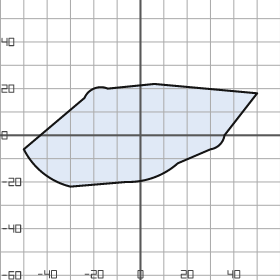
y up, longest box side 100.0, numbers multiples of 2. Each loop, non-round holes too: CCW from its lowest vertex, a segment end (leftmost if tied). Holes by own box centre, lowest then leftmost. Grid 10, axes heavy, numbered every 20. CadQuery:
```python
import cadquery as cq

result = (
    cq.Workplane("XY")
    .moveTo(-30.0, -22.0)
    .lineTo(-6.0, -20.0)
    .threePointArc((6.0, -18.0), (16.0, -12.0))
    .lineTo(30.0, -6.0)
    .threePointArc((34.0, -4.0), (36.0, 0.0))
    .lineTo(50.0, 18.0)
    .lineTo(6.0, 22.0)
    .lineTo(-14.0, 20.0)
    .threePointArc((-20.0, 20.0), (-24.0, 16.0))
    .lineTo(-50.0, -6.0)
    .threePointArc((-42.0, -16.0), (-30.0, -22.0))
    .close()
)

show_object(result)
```